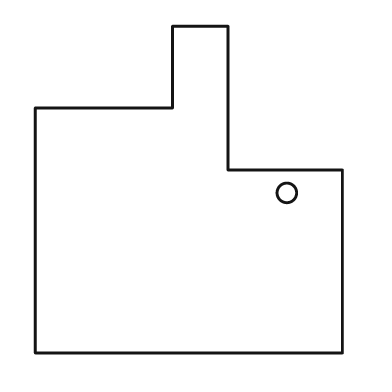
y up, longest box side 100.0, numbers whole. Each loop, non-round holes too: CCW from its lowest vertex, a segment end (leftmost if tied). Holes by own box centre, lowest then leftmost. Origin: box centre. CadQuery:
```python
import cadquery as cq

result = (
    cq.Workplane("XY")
    .moveTo(-47.0, -50.0)
    .lineTo(47.0, -50.0)
    .lineTo(47.0, 6.0)
    .lineTo(12.0, 6.0)
    .lineTo(12.0, 50.0)
    .lineTo(-5.0, 50.0)
    .lineTo(-5.0, 25.0)
    .lineTo(-47.0, 25.0)
    .close()
    .moveTo(30.0, -1.0)
    .circle(3.0)
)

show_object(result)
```